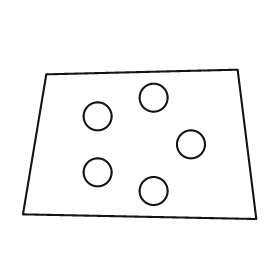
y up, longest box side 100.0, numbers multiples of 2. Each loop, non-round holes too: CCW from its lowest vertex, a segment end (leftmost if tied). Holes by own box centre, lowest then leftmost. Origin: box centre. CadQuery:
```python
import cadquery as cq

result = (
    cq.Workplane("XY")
    .moveTo(50.0, -32.0)
    .lineTo(42.0, 32.0)
    .lineTo(-40.0, 30.0)
    .lineTo(-50.0, -30.0)
    .close()
    .moveTo(6.0, -20.0)
    .circle(6.0)
    .moveTo(-18.0, -12.0)
    .circle(6.0)
    .moveTo(22.0, 0.0)
    .circle(6.0)
    .moveTo(-18.0, 12.0)
    .circle(6.0)
    .moveTo(6.0, 20.0)
    .circle(6.0)
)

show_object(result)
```